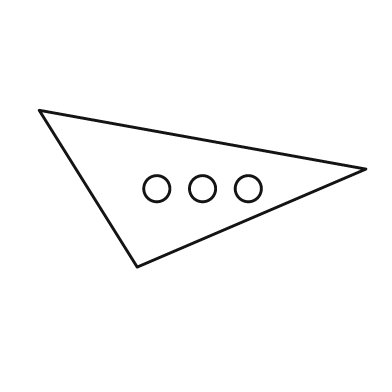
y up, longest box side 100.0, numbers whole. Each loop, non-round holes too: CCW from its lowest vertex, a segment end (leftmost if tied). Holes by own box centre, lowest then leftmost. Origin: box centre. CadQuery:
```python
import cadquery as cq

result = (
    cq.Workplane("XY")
    .moveTo(-20.0, -24.0)
    .lineTo(50.0, 6.0)
    .lineTo(-50.0, 24.0)
    .close()
    .moveTo(-14.0, 0.0)
    .circle(4.0)
    .moveTo(0.0, 0.0)
    .circle(4.0)
    .moveTo(14.0, 0.0)
    .circle(4.0)
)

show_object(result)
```